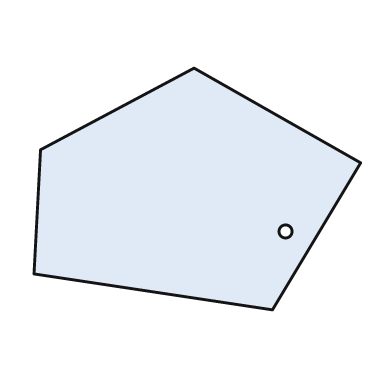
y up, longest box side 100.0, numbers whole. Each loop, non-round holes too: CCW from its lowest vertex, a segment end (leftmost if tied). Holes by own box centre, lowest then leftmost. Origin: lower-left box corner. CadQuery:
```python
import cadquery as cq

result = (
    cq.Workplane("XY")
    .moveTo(73.0, 0.0)
    .lineTo(100.0, 45.0)
    .lineTo(49.0, 74.0)
    .lineTo(2.0, 49.0)
    .lineTo(0.0, 11.0)
    .close()
    .moveTo(77.0, 24.0)
    .circle(2.0)
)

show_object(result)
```